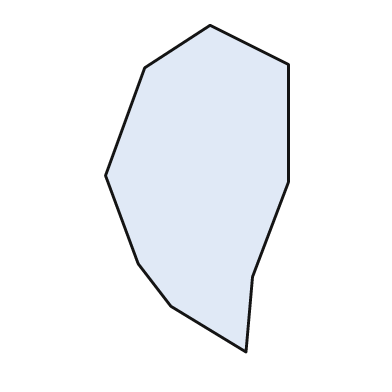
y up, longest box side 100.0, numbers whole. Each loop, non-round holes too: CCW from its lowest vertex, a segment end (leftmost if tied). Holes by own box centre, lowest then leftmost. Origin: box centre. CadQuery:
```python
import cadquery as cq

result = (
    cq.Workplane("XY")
    .moveTo(15.0, -50.0)
    .lineTo(17.0, -27.0)
    .lineTo(28.0, 2.0)
    .lineTo(28.0, 38.0)
    .lineTo(4.0, 50.0)
    .lineTo(-16.0, 37.0)
    .lineTo(-28.0, 4.0)
    .lineTo(-18.0, -23.0)
    .lineTo(-8.0, -36.0)
    .close()
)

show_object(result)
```